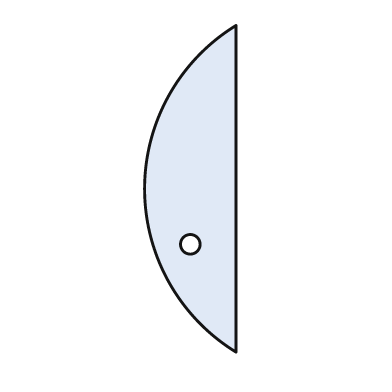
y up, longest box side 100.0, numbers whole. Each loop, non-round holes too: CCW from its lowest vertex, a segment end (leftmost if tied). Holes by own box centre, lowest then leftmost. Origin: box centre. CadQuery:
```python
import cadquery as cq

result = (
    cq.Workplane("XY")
    .moveTo(14.0, -50.0)
    .lineTo(14.0, 50.0)
    .threePointArc((-14.0, 0.0), (14.0, -50.0))
    .close()
    .moveTo(0.0, -17.0)
    .circle(3.0)
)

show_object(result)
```